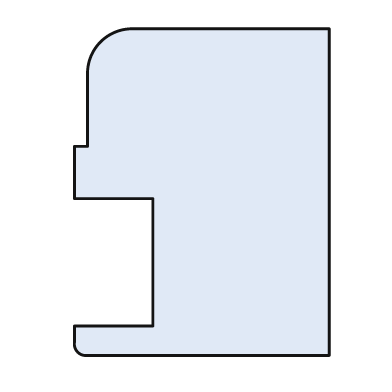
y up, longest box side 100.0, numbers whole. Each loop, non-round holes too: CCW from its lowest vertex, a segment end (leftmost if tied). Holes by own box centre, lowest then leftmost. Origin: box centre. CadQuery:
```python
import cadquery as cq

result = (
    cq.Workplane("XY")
    .moveTo(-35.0, -50.0)
    .lineTo(39.0, -50.0)
    .lineTo(39.0, 50.0)
    .lineTo(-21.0, 50.0)
    .threePointArc((-31.0, 46.0), (-35.0, 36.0))
    .lineTo(-35.0, 14.0)
    .lineTo(-39.0, 14.0)
    .lineTo(-39.0, -2.0)
    .lineTo(-15.0, -2.0)
    .lineTo(-15.0, -41.0)
    .lineTo(-39.0, -41.0)
    .lineTo(-39.0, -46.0)
    .threePointArc((-38.0, -49.0), (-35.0, -50.0))
    .close()
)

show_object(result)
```